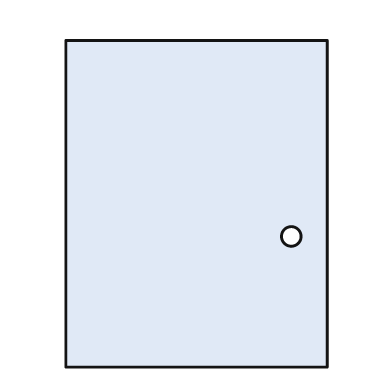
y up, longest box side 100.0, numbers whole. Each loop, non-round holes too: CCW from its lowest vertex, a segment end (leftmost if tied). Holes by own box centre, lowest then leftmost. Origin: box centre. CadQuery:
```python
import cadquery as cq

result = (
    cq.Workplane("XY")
    .moveTo(-40.0, -50.0)
    .lineTo(40.0, -50.0)
    .lineTo(40.0, 50.0)
    .lineTo(-40.0, 50.0)
    .close()
    .moveTo(29.0, -10.0)
    .circle(3.0)
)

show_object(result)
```